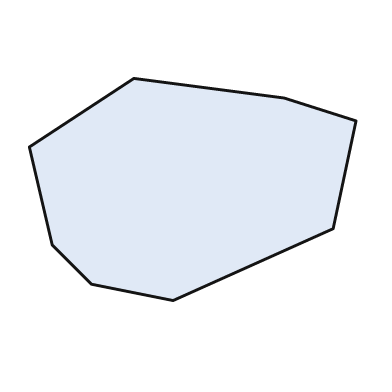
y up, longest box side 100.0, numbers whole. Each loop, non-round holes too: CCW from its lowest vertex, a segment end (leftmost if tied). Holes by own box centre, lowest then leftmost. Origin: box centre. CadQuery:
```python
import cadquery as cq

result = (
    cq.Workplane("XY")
    .moveTo(-6.0, -34.0)
    .lineTo(43.0, -12.0)
    .lineTo(50.0, 21.0)
    .lineTo(28.0, 28.0)
    .lineTo(-18.0, 34.0)
    .lineTo(-50.0, 13.0)
    .lineTo(-43.0, -17.0)
    .lineTo(-31.0, -29.0)
    .close()
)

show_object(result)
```